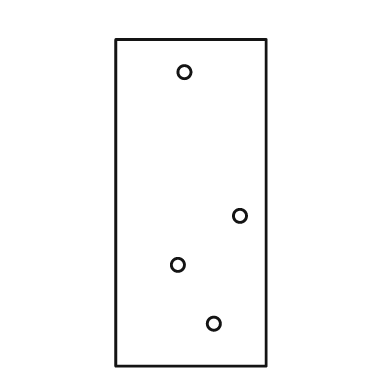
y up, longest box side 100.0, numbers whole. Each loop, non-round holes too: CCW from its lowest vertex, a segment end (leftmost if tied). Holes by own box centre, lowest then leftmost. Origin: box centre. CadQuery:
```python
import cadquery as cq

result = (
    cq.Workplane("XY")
    .moveTo(-23.0, -50.0)
    .lineTo(23.0, -50.0)
    .lineTo(23.0, 50.0)
    .lineTo(-23.0, 50.0)
    .close()
    .moveTo(7.0, -37.0)
    .circle(2.0)
    .moveTo(-4.0, -19.0)
    .circle(2.0)
    .moveTo(15.0, -4.0)
    .circle(2.0)
    .moveTo(-2.0, 40.0)
    .circle(2.0)
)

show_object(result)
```